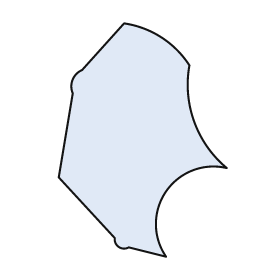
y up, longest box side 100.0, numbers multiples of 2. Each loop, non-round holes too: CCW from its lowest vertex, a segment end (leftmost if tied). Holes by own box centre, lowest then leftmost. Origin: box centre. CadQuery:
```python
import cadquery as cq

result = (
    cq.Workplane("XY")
    .moveTo(10.0, -50.0)
    .threePointArc((10.0, -22.0), (36.0, -12.0))
    .threePointArc((22.0, 8.0), (20.0, 32.0))
    .threePointArc((8.0, 44.0), (-8.0, 50.0))
    .lineTo(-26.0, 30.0)
    .threePointArc((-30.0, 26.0), (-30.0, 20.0))
    .lineTo(-36.0, -16.0)
    .lineTo(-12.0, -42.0)
    .threePointArc((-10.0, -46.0), (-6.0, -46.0))
    .close()
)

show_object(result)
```